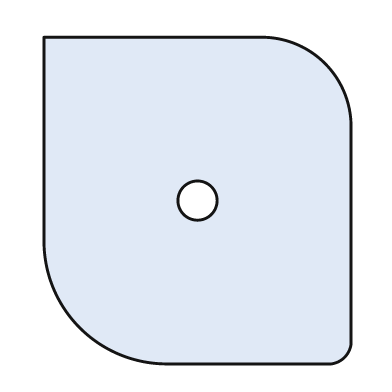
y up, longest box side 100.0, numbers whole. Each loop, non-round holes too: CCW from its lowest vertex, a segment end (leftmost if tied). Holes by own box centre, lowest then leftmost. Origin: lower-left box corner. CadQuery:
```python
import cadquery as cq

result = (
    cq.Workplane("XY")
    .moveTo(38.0, 0.0)
    .lineTo(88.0, 0.0)
    .threePointArc((92.0, 2.0), (94.0, 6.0))
    .lineTo(94.0, 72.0)
    .threePointArc((86.0, 92.0), (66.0, 100.0))
    .lineTo(0.0, 100.0)
    .lineTo(0.0, 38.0)
    .threePointArc((11.0, 11.0), (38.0, 0.0))
    .close()
    .moveTo(47.0, 50.0)
    .circle(6.0)
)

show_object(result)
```